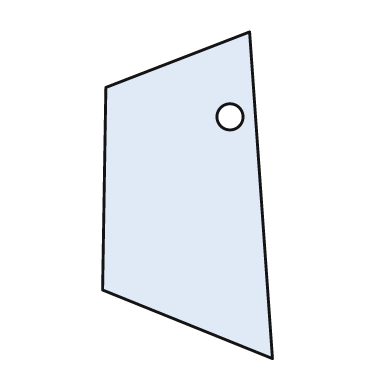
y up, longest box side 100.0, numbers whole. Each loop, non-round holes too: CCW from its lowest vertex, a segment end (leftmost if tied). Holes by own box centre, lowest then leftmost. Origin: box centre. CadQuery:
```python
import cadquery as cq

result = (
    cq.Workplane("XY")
    .moveTo(26.0, -50.0)
    .lineTo(19.0, 50.0)
    .lineTo(-25.0, 33.0)
    .lineTo(-26.0, -29.0)
    .close()
    .moveTo(13.0, 24.0)
    .circle(4.0)
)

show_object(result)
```